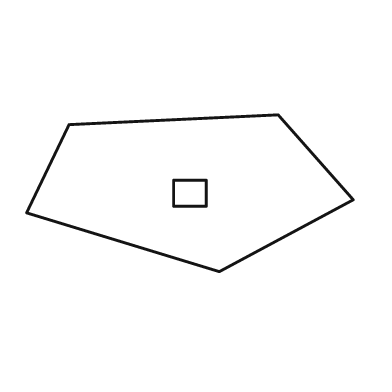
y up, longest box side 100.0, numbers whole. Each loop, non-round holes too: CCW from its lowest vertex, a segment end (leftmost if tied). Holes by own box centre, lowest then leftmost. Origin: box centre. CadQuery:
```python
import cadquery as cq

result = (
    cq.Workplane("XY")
    .moveTo(9.0, -24.0)
    .lineTo(50.0, -2.0)
    .lineTo(27.0, 24.0)
    .lineTo(-37.0, 21.0)
    .lineTo(-50.0, -6.0)
    .close()
    .moveTo(-5.0, -4.0)
    .lineTo(5.0, -4.0)
    .lineTo(5.0, 4.0)
    .lineTo(-5.0, 4.0)
    .close()
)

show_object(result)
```